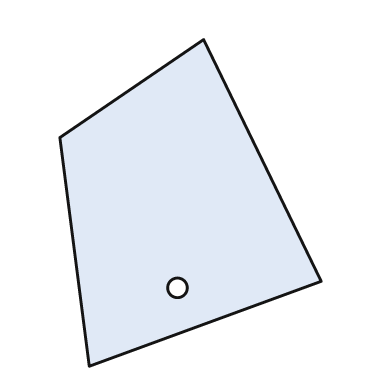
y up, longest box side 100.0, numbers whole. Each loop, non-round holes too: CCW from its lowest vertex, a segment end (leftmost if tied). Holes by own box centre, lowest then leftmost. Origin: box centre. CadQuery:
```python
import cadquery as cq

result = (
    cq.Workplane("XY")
    .moveTo(-31.0, -50.0)
    .lineTo(40.0, -24.0)
    .lineTo(4.0, 50.0)
    .lineTo(-40.0, 20.0)
    .close()
    .moveTo(-4.0, -26.0)
    .circle(3.0)
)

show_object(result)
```